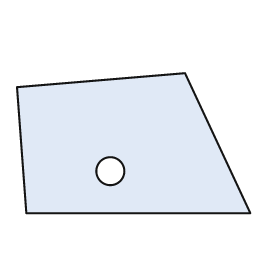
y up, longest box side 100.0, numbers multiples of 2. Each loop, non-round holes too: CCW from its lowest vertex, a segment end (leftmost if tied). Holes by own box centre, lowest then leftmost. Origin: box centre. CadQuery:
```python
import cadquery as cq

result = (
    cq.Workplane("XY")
    .moveTo(-46.0, -30.0)
    .lineTo(50.0, -30.0)
    .lineTo(22.0, 30.0)
    .lineTo(-50.0, 24.0)
    .close()
    .moveTo(-10.0, -12.0)
    .circle(6.0)
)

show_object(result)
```